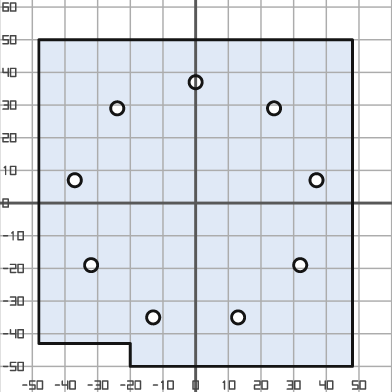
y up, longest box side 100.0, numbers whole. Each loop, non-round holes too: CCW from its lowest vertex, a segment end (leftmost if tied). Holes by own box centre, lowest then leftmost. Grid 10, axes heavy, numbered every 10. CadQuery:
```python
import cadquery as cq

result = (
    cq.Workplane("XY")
    .moveTo(-20.0, -50.0)
    .lineTo(48.0, -50.0)
    .lineTo(48.0, 50.0)
    .lineTo(-48.0, 50.0)
    .lineTo(-48.0, -43.0)
    .lineTo(-20.0, -43.0)
    .close()
    .moveTo(-13.0, -35.0)
    .circle(2.0)
    .moveTo(13.0, -35.0)
    .circle(2.0)
    .moveTo(-32.0, -19.0)
    .circle(2.0)
    .moveTo(32.0, -19.0)
    .circle(2.0)
    .moveTo(-37.0, 7.0)
    .circle(2.0)
    .moveTo(37.0, 7.0)
    .circle(2.0)
    .moveTo(-24.0, 29.0)
    .circle(2.0)
    .moveTo(24.0, 29.0)
    .circle(2.0)
    .moveTo(0.0, 37.0)
    .circle(2.0)
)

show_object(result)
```